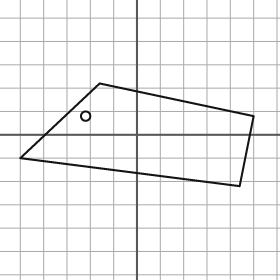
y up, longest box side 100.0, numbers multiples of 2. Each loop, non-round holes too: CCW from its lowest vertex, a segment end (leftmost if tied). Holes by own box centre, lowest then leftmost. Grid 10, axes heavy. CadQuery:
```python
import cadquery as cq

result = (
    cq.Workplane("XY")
    .moveTo(44.0, -22.0)
    .lineTo(50.0, 8.0)
    .lineTo(-16.0, 22.0)
    .lineTo(-50.0, -10.0)
    .close()
    .moveTo(-22.0, 8.0)
    .circle(2.0)
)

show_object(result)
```